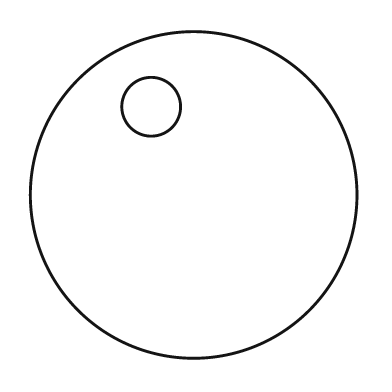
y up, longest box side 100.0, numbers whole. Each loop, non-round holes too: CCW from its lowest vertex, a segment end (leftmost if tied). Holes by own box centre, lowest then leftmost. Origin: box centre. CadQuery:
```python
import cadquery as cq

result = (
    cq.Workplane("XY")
    .moveTo(0.0, 0.0)
    .circle(50.0)
    .moveTo(-13.0, 27.0)
    .circle(9.0)
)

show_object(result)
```